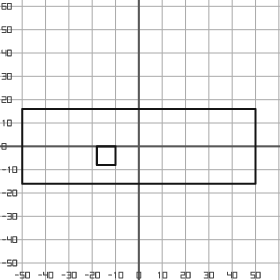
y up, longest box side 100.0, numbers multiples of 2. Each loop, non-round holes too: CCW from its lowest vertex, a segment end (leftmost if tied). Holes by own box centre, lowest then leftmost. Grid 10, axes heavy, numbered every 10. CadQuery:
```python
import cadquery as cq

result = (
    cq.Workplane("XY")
    .moveTo(-50.0, -16.0)
    .lineTo(50.0, -16.0)
    .lineTo(50.0, 16.0)
    .lineTo(-50.0, 16.0)
    .close()
    .moveTo(-18.0, -8.0)
    .lineTo(-10.0, -8.0)
    .lineTo(-10.0, 0.0)
    .lineTo(-18.0, 0.0)
    .close()
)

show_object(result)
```